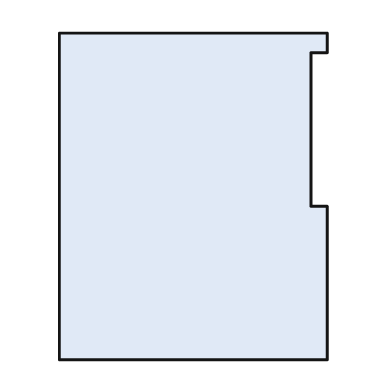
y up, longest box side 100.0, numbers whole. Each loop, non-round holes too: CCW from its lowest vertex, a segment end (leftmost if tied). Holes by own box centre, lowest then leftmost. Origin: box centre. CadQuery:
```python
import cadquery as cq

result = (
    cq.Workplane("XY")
    .moveTo(-41.0, -50.0)
    .lineTo(41.0, -50.0)
    .lineTo(41.0, -3.0)
    .lineTo(36.0, -3.0)
    .lineTo(36.0, 44.0)
    .lineTo(41.0, 44.0)
    .lineTo(41.0, 50.0)
    .lineTo(-41.0, 50.0)
    .close()
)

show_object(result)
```